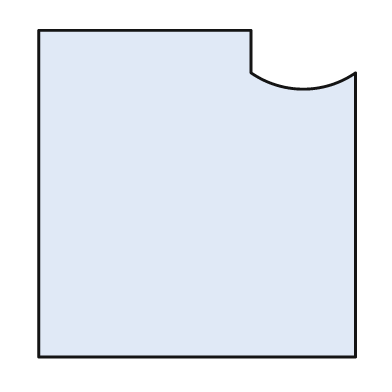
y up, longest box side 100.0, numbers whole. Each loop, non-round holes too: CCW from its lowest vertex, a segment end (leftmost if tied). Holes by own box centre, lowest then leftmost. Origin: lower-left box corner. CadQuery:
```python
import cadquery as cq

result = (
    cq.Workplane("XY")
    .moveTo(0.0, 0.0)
    .lineTo(97.0, 0.0)
    .lineTo(97.0, 87.0)
    .threePointArc((81.0, 82.0), (65.0, 87.0))
    .lineTo(65.0, 100.0)
    .lineTo(0.0, 100.0)
    .close()
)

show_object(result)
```